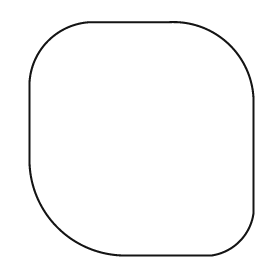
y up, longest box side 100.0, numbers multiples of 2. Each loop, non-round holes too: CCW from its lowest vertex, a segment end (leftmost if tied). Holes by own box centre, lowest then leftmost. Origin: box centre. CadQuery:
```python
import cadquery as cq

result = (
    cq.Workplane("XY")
    .moveTo(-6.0, -50.0)
    .lineTo(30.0, -50.0)
    .threePointArc((42.0, -44.0), (48.0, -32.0))
    .lineTo(48.0, 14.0)
    .threePointArc((38.0, 40.0), (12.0, 50.0))
    .lineTo(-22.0, 50.0)
    .threePointArc((-40.0, 42.0), (-48.0, 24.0))
    .lineTo(-48.0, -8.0)
    .threePointArc((-36.0, -38.0), (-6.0, -50.0))
    .close()
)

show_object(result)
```